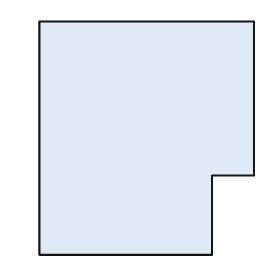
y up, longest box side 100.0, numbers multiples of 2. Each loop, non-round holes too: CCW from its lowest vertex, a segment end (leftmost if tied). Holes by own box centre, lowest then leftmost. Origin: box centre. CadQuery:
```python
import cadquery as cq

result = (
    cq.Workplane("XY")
    .moveTo(-46.0, -50.0)
    .lineTo(28.0, -50.0)
    .lineTo(28.0, -16.0)
    .lineTo(46.0, -16.0)
    .lineTo(46.0, 50.0)
    .lineTo(-46.0, 50.0)
    .close()
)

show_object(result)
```